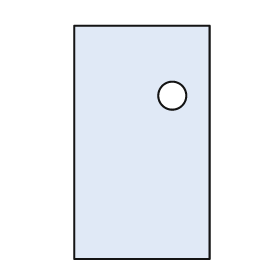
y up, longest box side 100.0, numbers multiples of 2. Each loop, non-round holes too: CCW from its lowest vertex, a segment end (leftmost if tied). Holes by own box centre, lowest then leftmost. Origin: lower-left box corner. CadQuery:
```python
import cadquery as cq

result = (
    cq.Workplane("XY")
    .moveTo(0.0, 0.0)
    .lineTo(58.0, 0.0)
    .lineTo(58.0, 100.0)
    .lineTo(0.0, 100.0)
    .close()
    .moveTo(42.0, 70.0)
    .circle(6.0)
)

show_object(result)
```